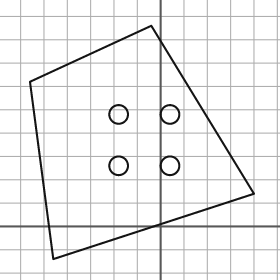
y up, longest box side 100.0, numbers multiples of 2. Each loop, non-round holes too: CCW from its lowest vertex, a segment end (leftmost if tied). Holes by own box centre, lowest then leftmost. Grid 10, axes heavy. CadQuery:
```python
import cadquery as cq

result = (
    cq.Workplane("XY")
    .moveTo(-46.0, -14.0)
    .lineTo(40.0, 14.0)
    .lineTo(-4.0, 86.0)
    .lineTo(-56.0, 62.0)
    .close()
    .moveTo(-18.0, 26.0)
    .circle(4.0)
    .moveTo(4.0, 26.0)
    .circle(4.0)
    .moveTo(-18.0, 48.0)
    .circle(4.0)
    .moveTo(4.0, 48.0)
    .circle(4.0)
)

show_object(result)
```